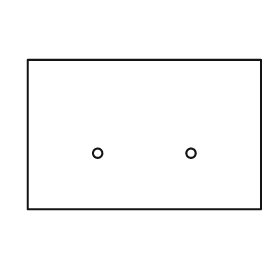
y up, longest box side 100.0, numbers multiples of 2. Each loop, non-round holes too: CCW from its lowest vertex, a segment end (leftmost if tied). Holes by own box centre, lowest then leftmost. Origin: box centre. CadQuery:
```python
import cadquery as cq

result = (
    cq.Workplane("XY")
    .moveTo(-50.0, -32.0)
    .lineTo(50.0, -32.0)
    .lineTo(50.0, 32.0)
    .lineTo(-50.0, 32.0)
    .close()
    .moveTo(-20.0, -8.0)
    .circle(2.0)
    .moveTo(20.0, -8.0)
    .circle(2.0)
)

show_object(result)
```